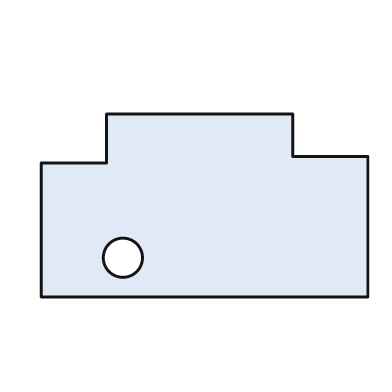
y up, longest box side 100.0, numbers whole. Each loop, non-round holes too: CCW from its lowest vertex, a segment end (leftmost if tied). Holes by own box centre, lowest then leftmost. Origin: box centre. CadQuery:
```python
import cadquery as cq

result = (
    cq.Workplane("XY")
    .moveTo(-50.0, -28.0)
    .lineTo(50.0, -28.0)
    .lineTo(50.0, 15.0)
    .lineTo(27.0, 15.0)
    .lineTo(27.0, 28.0)
    .lineTo(-30.0, 28.0)
    .lineTo(-30.0, 13.0)
    .lineTo(-50.0, 13.0)
    .close()
    .moveTo(-25.0, -16.0)
    .circle(6.0)
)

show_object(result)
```